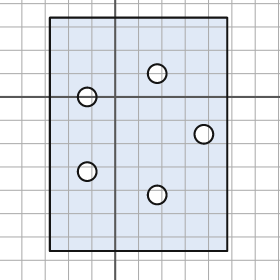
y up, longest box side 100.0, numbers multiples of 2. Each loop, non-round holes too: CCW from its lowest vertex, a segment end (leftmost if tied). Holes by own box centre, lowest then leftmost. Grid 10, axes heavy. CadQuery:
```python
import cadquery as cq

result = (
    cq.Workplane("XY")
    .moveTo(-28.0, -66.0)
    .lineTo(48.0, -66.0)
    .lineTo(48.0, 34.0)
    .lineTo(-28.0, 34.0)
    .close()
    .moveTo(18.0, -42.0)
    .circle(4.0)
    .moveTo(-12.0, -32.0)
    .circle(4.0)
    .moveTo(38.0, -16.0)
    .circle(4.0)
    .moveTo(-12.0, 0.0)
    .circle(4.0)
    .moveTo(18.0, 10.0)
    .circle(4.0)
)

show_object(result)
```